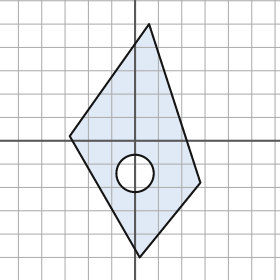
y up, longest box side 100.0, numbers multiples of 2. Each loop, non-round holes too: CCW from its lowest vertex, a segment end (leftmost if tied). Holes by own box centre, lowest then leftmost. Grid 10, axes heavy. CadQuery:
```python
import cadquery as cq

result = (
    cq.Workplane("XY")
    .moveTo(2.0, -50.0)
    .lineTo(28.0, -18.0)
    .lineTo(6.0, 50.0)
    .lineTo(-28.0, 2.0)
    .close()
    .moveTo(0.0, -14.0)
    .circle(8.0)
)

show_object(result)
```